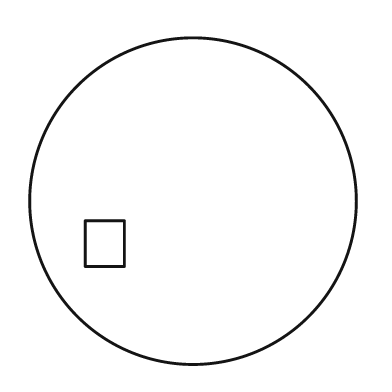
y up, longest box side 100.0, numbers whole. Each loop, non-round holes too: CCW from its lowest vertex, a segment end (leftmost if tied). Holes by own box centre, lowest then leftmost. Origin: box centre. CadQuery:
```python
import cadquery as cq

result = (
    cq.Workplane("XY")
    .moveTo(0.0, 0.0)
    .circle(50.0)
    .moveTo(-33.0, -20.0)
    .lineTo(-21.0, -20.0)
    .lineTo(-21.0, -6.0)
    .lineTo(-33.0, -6.0)
    .close()
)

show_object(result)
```